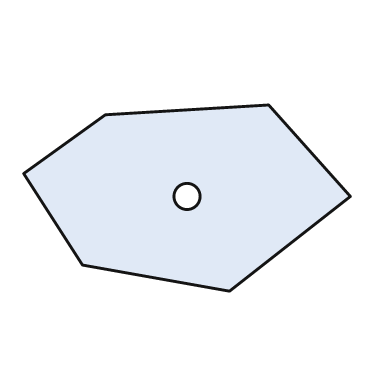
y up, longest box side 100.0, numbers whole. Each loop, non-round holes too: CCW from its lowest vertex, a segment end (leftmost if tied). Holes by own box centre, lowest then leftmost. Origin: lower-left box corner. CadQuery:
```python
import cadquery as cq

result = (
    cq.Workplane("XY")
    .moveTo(63.0, 0.0)
    .lineTo(100.0, 29.0)
    .lineTo(75.0, 57.0)
    .lineTo(25.0, 54.0)
    .lineTo(0.0, 36.0)
    .lineTo(18.0, 8.0)
    .close()
    .moveTo(50.0, 29.0)
    .circle(4.0)
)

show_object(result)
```